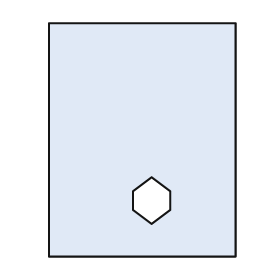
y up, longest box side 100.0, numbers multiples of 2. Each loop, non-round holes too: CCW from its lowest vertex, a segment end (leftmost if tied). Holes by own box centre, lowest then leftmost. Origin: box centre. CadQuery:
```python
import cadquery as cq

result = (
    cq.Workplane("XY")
    .moveTo(-40.0, -50.0)
    .lineTo(40.0, -50.0)
    .lineTo(40.0, 50.0)
    .lineTo(-40.0, 50.0)
    .close()
    .moveTo(4.0, -36.0)
    .lineTo(12.0, -30.0)
    .lineTo(12.0, -22.0)
    .lineTo(4.0, -16.0)
    .lineTo(-4.0, -22.0)
    .lineTo(-4.0, -30.0)
    .close()
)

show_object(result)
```